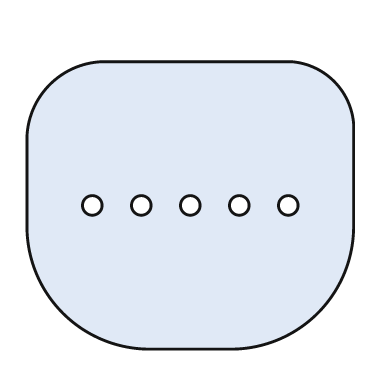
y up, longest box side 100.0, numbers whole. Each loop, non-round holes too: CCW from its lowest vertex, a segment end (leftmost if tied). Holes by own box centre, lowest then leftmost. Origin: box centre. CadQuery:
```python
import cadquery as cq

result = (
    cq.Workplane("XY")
    .moveTo(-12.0, -44.0)
    .lineTo(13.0, -44.0)
    .threePointArc((39.0, -33.0), (50.0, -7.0))
    .lineTo(50.0, 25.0)
    .threePointArc((44.0, 38.0), (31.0, 44.0))
    .lineTo(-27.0, 44.0)
    .threePointArc((-43.0, 37.0), (-50.0, 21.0))
    .lineTo(-50.0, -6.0)
    .threePointArc((-39.0, -33.0), (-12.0, -44.0))
    .close()
    .moveTo(-30.0, 0.0)
    .circle(3.0)
    .moveTo(-15.0, 0.0)
    .circle(3.0)
    .moveTo(0.0, 0.0)
    .circle(3.0)
    .moveTo(15.0, 0.0)
    .circle(3.0)
    .moveTo(30.0, 0.0)
    .circle(3.0)
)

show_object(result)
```